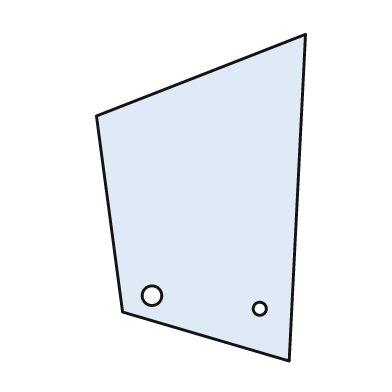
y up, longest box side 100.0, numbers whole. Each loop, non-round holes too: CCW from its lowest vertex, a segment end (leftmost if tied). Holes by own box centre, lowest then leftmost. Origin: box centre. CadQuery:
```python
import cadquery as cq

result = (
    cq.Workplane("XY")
    .moveTo(27.0, -50.0)
    .lineTo(32.0, 50.0)
    .lineTo(-32.0, 25.0)
    .lineTo(-24.0, -35.0)
    .close()
    .moveTo(18.0, -34.0)
    .circle(2.0)
    .moveTo(-15.0, -30.0)
    .circle(3.0)
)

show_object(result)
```